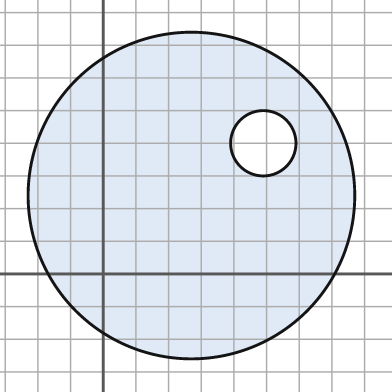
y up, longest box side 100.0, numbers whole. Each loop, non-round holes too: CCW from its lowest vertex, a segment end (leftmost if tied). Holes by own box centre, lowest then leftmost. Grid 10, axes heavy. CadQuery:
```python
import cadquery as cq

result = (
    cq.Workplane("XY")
    .moveTo(27.0, 24.0)
    .circle(50.0)
    .moveTo(49.0, 40.0)
    .circle(10.0)
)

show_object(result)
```